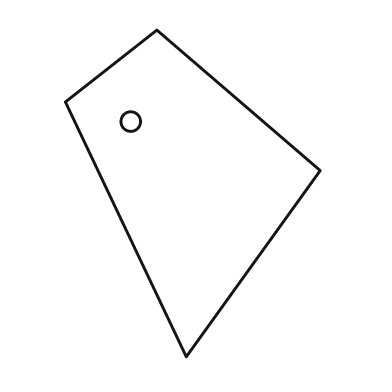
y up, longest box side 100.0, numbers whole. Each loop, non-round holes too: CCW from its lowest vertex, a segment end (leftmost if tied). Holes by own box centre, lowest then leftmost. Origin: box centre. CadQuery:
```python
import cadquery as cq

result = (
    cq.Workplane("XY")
    .moveTo(-2.0, -50.0)
    .lineTo(39.0, 7.0)
    .lineTo(-11.0, 50.0)
    .lineTo(-39.0, 28.0)
    .close()
    .moveTo(-19.0, 22.0)
    .circle(3.0)
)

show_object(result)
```